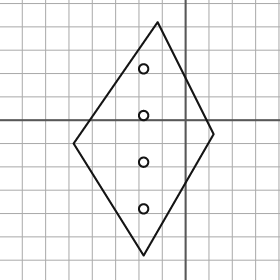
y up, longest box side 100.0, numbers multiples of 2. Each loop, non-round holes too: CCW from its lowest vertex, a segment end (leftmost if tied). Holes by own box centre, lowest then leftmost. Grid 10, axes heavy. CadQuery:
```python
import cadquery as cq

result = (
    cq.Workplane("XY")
    .moveTo(-18.0, -58.0)
    .lineTo(12.0, -6.0)
    .lineTo(-12.0, 42.0)
    .lineTo(-48.0, -10.0)
    .close()
    .moveTo(-18.0, -38.0)
    .circle(2.0)
    .moveTo(-18.0, -18.0)
    .circle(2.0)
    .moveTo(-18.0, 2.0)
    .circle(2.0)
    .moveTo(-18.0, 22.0)
    .circle(2.0)
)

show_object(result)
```